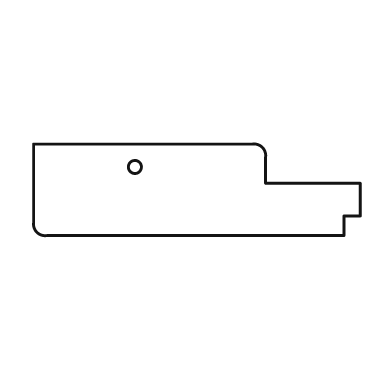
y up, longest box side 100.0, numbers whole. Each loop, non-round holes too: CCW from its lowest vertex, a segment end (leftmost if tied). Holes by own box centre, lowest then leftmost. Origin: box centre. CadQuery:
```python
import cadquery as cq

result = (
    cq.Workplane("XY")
    .moveTo(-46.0, -14.0)
    .lineTo(45.0, -14.0)
    .lineTo(45.0, -8.0)
    .lineTo(50.0, -8.0)
    .lineTo(50.0, 2.0)
    .lineTo(21.0, 2.0)
    .lineTo(21.0, 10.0)
    .threePointArc((20.0, 13.0), (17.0, 14.0))
    .lineTo(-50.0, 14.0)
    .lineTo(-50.0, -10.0)
    .threePointArc((-49.0, -13.0), (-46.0, -14.0))
    .close()
    .moveTo(-19.0, 7.0)
    .circle(2.0)
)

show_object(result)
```